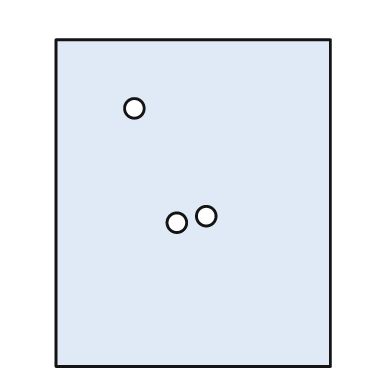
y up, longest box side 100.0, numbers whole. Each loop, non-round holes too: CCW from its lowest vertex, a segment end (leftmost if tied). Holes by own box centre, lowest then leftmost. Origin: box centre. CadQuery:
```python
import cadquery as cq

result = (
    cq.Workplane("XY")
    .moveTo(-42.0, -50.0)
    .lineTo(42.0, -50.0)
    .lineTo(42.0, 50.0)
    .lineTo(-42.0, 50.0)
    .close()
    .moveTo(-5.0, -6.0)
    .circle(3.0)
    .moveTo(4.0, -4.0)
    .circle(3.0)
    .moveTo(-18.0, 29.0)
    .circle(3.0)
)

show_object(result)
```